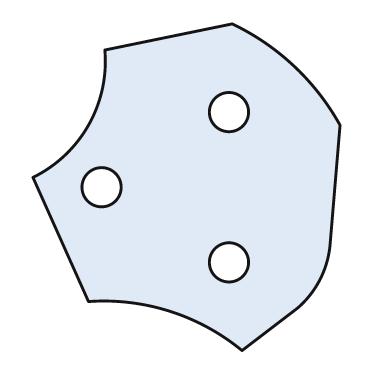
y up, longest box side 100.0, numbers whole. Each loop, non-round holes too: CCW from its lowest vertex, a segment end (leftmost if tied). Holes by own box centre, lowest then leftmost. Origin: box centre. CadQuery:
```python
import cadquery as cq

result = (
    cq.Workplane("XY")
    .moveTo(17.0, -50.0)
    .lineTo(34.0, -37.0)
    .threePointArc((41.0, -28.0), (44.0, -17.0))
    .lineTo(47.0, 19.0)
    .threePointArc((33.0, 37.0), (14.0, 50.0))
    .lineTo(-25.0, 42.0)
    .threePointArc((-30.0, 19.0), (-47.0, 3.0))
    .lineTo(-30.0, -35.0)
    .threePointArc((-5.0, -38.0), (17.0, -50.0))
    .close()
    .moveTo(13.0, -23.0)
    .circle(6.0)
    .moveTo(-26.0, 0.0)
    .circle(6.0)
    .moveTo(13.0, 23.0)
    .circle(6.0)
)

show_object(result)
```